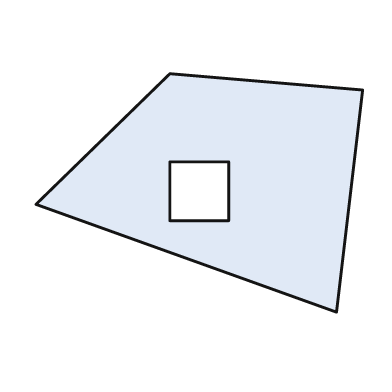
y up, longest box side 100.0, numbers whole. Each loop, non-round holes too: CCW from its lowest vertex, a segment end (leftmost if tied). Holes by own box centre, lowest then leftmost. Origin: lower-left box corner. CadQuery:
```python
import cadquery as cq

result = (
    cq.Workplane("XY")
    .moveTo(92.0, 0.0)
    .lineTo(100.0, 68.0)
    .lineTo(41.0, 73.0)
    .lineTo(0.0, 33.0)
    .close()
    .moveTo(41.0, 28.0)
    .lineTo(59.0, 28.0)
    .lineTo(59.0, 46.0)
    .lineTo(41.0, 46.0)
    .close()
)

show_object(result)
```